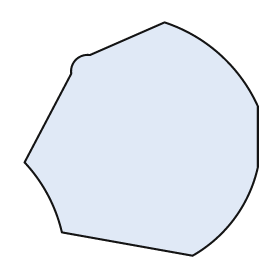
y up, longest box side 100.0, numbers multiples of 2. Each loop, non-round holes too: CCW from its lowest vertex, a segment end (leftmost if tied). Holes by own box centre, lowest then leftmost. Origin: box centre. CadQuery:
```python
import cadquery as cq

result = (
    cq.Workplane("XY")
    .moveTo(22.0, -50.0)
    .threePointArc((40.0, -34.0), (50.0, -12.0))
    .lineTo(50.0, 14.0)
    .threePointArc((34.0, 36.0), (10.0, 50.0))
    .lineTo(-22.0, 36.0)
    .threePointArc((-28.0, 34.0), (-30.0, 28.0))
    .lineTo(-50.0, -10.0)
    .threePointArc((-40.0, -24.0), (-34.0, -40.0))
    .close()
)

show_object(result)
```